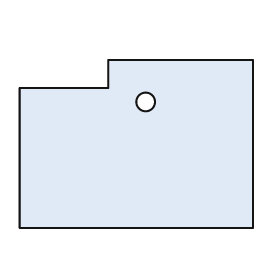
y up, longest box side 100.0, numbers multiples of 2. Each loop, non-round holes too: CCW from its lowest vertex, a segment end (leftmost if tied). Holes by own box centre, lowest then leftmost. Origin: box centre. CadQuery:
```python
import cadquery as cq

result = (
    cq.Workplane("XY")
    .moveTo(-50.0, -36.0)
    .lineTo(50.0, -36.0)
    .lineTo(50.0, 36.0)
    .lineTo(-12.0, 36.0)
    .lineTo(-12.0, 24.0)
    .lineTo(-50.0, 24.0)
    .close()
    .moveTo(4.0, 18.0)
    .circle(4.0)
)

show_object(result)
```